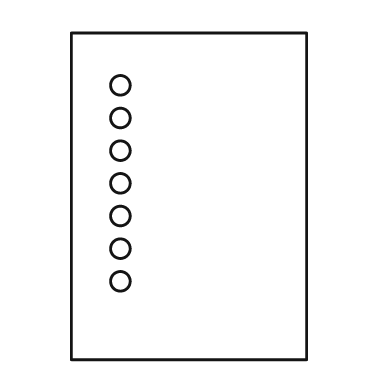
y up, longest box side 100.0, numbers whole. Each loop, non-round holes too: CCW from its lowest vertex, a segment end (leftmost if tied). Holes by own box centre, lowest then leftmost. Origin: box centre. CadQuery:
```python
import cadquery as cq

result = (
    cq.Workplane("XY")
    .moveTo(-36.0, -50.0)
    .lineTo(36.0, -50.0)
    .lineTo(36.0, 50.0)
    .lineTo(-36.0, 50.0)
    .close()
    .moveTo(-21.0, -26.0)
    .circle(3.0)
    .moveTo(-21.0, -16.0)
    .circle(3.0)
    .moveTo(-21.0, -6.0)
    .circle(3.0)
    .moveTo(-21.0, 4.0)
    .circle(3.0)
    .moveTo(-21.0, 14.0)
    .circle(3.0)
    .moveTo(-21.0, 24.0)
    .circle(3.0)
    .moveTo(-21.0, 34.0)
    .circle(3.0)
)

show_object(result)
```